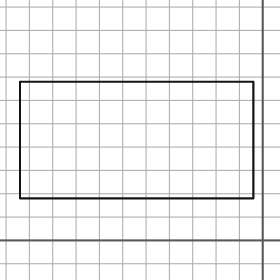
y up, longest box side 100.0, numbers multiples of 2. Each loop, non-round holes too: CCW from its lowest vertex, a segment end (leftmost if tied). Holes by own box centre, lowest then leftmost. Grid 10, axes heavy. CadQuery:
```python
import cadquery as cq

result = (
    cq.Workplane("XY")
    .moveTo(-104.0, 18.0)
    .lineTo(-4.0, 18.0)
    .lineTo(-4.0, 68.0)
    .lineTo(-104.0, 68.0)
    .close()
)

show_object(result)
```